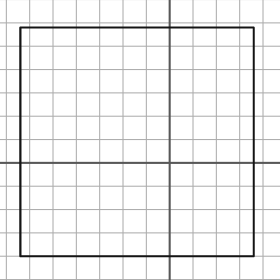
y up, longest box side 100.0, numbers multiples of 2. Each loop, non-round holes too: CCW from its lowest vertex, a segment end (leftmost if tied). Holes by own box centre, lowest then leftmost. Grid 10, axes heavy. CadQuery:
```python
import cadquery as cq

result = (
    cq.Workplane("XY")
    .moveTo(-64.0, -40.0)
    .lineTo(36.0, -40.0)
    .lineTo(36.0, 58.0)
    .lineTo(-64.0, 58.0)
    .close()
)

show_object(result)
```